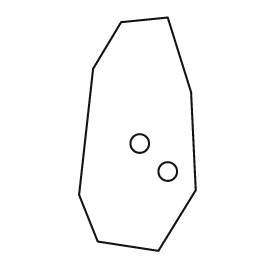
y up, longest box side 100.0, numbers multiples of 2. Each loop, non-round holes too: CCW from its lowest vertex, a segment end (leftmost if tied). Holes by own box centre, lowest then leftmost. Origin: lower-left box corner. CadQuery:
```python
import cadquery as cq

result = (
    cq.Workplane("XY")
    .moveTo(34.0, 0.0)
    .lineTo(50.0, 26.0)
    .lineTo(48.0, 68.0)
    .lineTo(38.0, 100.0)
    .lineTo(18.0, 98.0)
    .lineTo(6.0, 78.0)
    .lineTo(0.0, 24.0)
    .lineTo(8.0, 4.0)
    .close()
    .moveTo(38.0, 34.0)
    .circle(4.0)
    .moveTo(26.0, 46.0)
    .circle(4.0)
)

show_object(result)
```